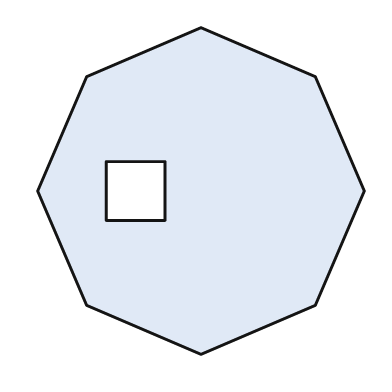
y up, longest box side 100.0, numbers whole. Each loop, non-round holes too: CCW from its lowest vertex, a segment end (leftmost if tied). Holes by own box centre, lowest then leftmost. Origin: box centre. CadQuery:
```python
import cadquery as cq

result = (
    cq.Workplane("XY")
    .moveTo(0.0, -50.0)
    .lineTo(35.0, -35.0)
    .lineTo(50.0, 0.0)
    .lineTo(35.0, 35.0)
    .lineTo(0.0, 50.0)
    .lineTo(-35.0, 35.0)
    .lineTo(-50.0, 0.0)
    .lineTo(-35.0, -35.0)
    .close()
    .moveTo(-29.0, -9.0)
    .lineTo(-11.0, -9.0)
    .lineTo(-11.0, 9.0)
    .lineTo(-29.0, 9.0)
    .close()
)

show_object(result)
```